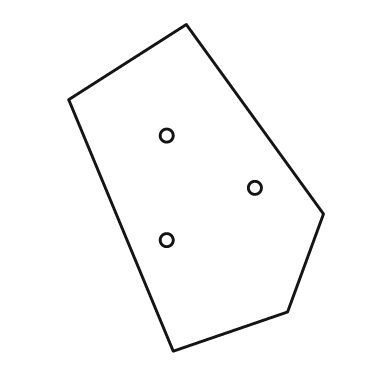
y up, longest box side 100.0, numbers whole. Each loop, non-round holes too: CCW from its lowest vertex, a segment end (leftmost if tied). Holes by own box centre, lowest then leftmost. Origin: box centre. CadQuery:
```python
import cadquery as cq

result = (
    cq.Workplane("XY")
    .moveTo(-7.0, -50.0)
    .lineTo(28.0, -38.0)
    .lineTo(39.0, -8.0)
    .lineTo(-3.0, 50.0)
    .lineTo(-39.0, 27.0)
    .close()
    .moveTo(-9.0, -16.0)
    .circle(2.0)
    .moveTo(18.0, 0.0)
    .circle(2.0)
    .moveTo(-9.0, 16.0)
    .circle(2.0)
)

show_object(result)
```